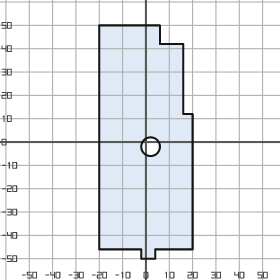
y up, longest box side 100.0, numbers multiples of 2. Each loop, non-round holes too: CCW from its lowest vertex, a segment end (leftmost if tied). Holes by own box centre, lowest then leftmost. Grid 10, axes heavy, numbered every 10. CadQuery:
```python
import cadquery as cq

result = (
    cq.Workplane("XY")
    .moveTo(-2.0, -50.0)
    .lineTo(4.0, -50.0)
    .lineTo(4.0, -46.0)
    .lineTo(20.0, -46.0)
    .lineTo(20.0, 12.0)
    .lineTo(16.0, 12.0)
    .lineTo(16.0, 42.0)
    .lineTo(6.0, 42.0)
    .lineTo(6.0, 50.0)
    .lineTo(-20.0, 50.0)
    .lineTo(-20.0, -46.0)
    .lineTo(-2.0, -46.0)
    .close()
    .moveTo(2.0, -2.0)
    .circle(4.0)
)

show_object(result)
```